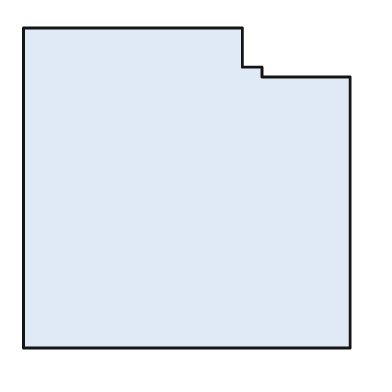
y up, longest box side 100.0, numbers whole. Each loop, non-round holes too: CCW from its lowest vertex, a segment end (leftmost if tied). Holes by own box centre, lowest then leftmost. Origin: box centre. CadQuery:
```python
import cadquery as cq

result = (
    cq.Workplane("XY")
    .moveTo(-50.0, -49.0)
    .lineTo(50.0, -49.0)
    .lineTo(50.0, 34.0)
    .lineTo(23.0, 34.0)
    .lineTo(23.0, 37.0)
    .lineTo(17.0, 37.0)
    .lineTo(17.0, 49.0)
    .lineTo(-50.0, 49.0)
    .close()
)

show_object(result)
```